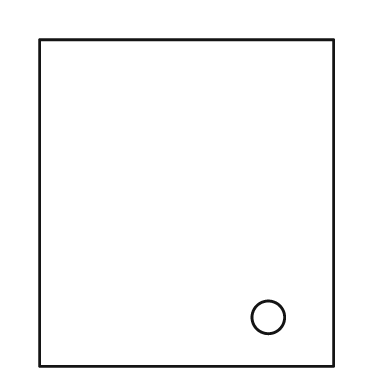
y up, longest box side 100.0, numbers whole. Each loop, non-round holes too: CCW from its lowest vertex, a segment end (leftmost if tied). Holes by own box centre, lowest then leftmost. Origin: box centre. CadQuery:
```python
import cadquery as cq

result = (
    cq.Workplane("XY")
    .moveTo(-45.0, -50.0)
    .lineTo(45.0, -50.0)
    .lineTo(45.0, 50.0)
    .lineTo(-45.0, 50.0)
    .close()
    .moveTo(25.0, -35.0)
    .circle(5.0)
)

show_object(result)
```